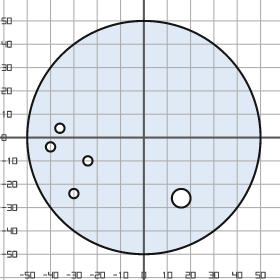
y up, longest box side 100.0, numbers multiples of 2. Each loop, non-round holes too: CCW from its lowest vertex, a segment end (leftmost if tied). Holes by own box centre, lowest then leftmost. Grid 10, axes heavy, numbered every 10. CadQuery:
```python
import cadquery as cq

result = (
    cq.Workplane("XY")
    .moveTo(0.0, 0.0)
    .circle(50.0)
    .moveTo(16.0, -26.0)
    .circle(4.0)
    .moveTo(-30.0, -24.0)
    .circle(2.0)
    .moveTo(-24.0, -10.0)
    .circle(2.0)
    .moveTo(-40.0, -4.0)
    .circle(2.0)
    .moveTo(-36.0, 4.0)
    .circle(2.0)
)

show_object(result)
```